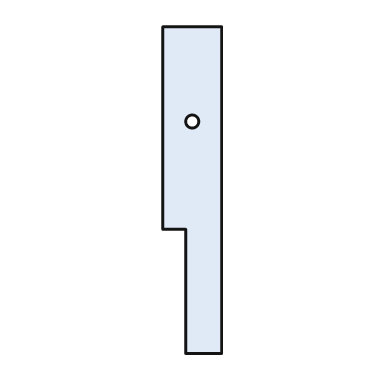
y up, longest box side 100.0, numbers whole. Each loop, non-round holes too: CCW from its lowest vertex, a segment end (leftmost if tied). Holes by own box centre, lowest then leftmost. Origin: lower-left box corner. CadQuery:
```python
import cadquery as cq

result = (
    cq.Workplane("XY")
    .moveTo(7.0, 0.0)
    .lineTo(18.0, 0.0)
    .lineTo(18.0, 100.0)
    .lineTo(0.0, 100.0)
    .lineTo(0.0, 38.0)
    .lineTo(7.0, 38.0)
    .close()
    .moveTo(9.0, 71.0)
    .circle(2.0)
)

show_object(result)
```